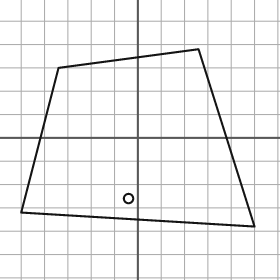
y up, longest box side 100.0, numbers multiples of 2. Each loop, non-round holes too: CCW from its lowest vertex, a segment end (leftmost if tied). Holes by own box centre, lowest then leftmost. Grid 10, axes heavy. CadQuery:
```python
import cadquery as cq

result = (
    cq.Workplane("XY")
    .moveTo(50.0, -38.0)
    .lineTo(26.0, 38.0)
    .lineTo(-34.0, 30.0)
    .lineTo(-50.0, -32.0)
    .close()
    .moveTo(-4.0, -26.0)
    .circle(2.0)
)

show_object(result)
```